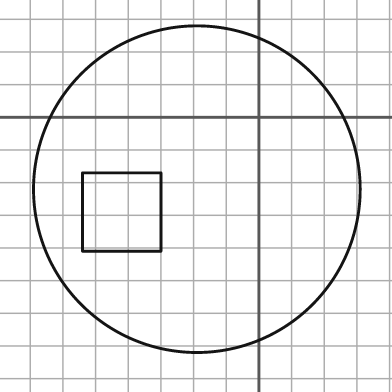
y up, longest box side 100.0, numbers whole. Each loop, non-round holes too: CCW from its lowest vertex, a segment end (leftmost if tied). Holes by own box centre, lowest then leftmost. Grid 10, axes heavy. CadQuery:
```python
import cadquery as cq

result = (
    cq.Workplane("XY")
    .moveTo(-19.0, -22.0)
    .circle(50.0)
    .moveTo(-54.0, -41.0)
    .lineTo(-30.0, -41.0)
    .lineTo(-30.0, -17.0)
    .lineTo(-54.0, -17.0)
    .close()
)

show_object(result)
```